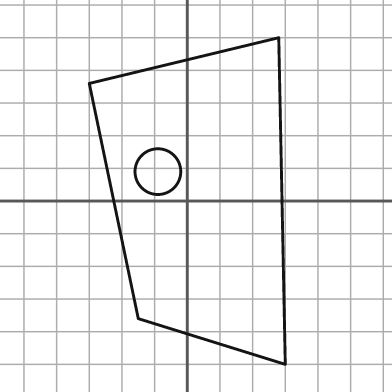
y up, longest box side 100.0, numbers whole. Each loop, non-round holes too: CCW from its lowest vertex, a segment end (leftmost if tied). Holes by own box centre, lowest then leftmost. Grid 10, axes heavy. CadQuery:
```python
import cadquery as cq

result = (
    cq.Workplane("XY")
    .moveTo(30.0, -50.0)
    .lineTo(28.0, 50.0)
    .lineTo(-30.0, 36.0)
    .lineTo(-15.0, -36.0)
    .close()
    .moveTo(-9.0, 9.0)
    .circle(7.0)
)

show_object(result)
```